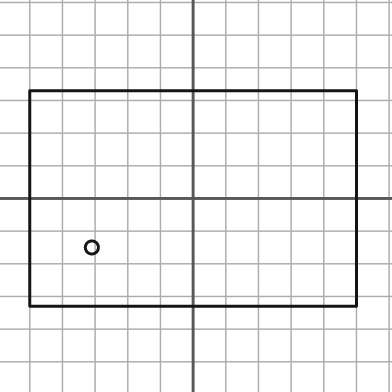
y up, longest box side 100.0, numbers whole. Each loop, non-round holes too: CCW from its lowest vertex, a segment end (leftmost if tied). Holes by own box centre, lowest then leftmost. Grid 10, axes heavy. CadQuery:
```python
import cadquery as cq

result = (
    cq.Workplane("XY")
    .moveTo(-50.0, -33.0)
    .lineTo(50.0, -33.0)
    .lineTo(50.0, 33.0)
    .lineTo(-50.0, 33.0)
    .close()
    .moveTo(-31.0, -15.0)
    .circle(2.0)
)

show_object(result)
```